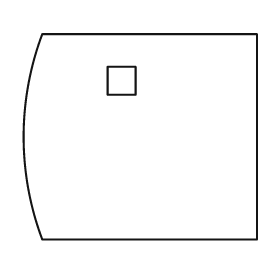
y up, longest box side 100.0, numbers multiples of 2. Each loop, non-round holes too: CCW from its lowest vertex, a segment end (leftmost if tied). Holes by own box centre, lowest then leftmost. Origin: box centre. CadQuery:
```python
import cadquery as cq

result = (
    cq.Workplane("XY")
    .moveTo(-42.0, -44.0)
    .lineTo(50.0, -44.0)
    .lineTo(50.0, 44.0)
    .lineTo(-42.0, 44.0)
    .threePointArc((-50.0, 0.0), (-42.0, -44.0))
    .close()
    .moveTo(-14.0, 18.0)
    .lineTo(-2.0, 18.0)
    .lineTo(-2.0, 30.0)
    .lineTo(-14.0, 30.0)
    .close()
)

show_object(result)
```